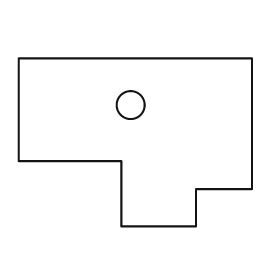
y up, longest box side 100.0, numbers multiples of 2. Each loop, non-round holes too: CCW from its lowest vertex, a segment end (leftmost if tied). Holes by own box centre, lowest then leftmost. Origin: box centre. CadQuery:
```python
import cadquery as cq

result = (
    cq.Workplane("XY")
    .moveTo(-6.0, -36.0)
    .lineTo(26.0, -36.0)
    .lineTo(26.0, -20.0)
    .lineTo(50.0, -20.0)
    .lineTo(50.0, 36.0)
    .lineTo(-50.0, 36.0)
    .lineTo(-50.0, -8.0)
    .lineTo(-6.0, -8.0)
    .close()
    .moveTo(-2.0, 16.0)
    .circle(6.0)
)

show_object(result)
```